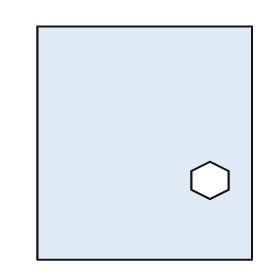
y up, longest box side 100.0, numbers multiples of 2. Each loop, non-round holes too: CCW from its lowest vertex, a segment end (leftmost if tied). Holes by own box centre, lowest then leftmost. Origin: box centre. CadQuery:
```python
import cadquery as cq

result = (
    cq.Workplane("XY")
    .moveTo(-46.0, -50.0)
    .lineTo(46.0, -50.0)
    .lineTo(46.0, 50.0)
    .lineTo(-46.0, 50.0)
    .close()
    .moveTo(28.0, -24.0)
    .lineTo(36.0, -20.0)
    .lineTo(36.0, -12.0)
    .lineTo(28.0, -8.0)
    .lineTo(20.0, -12.0)
    .lineTo(20.0, -20.0)
    .close()
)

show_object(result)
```